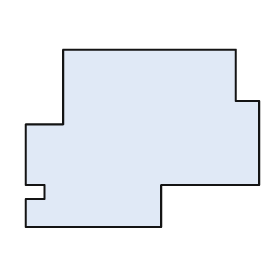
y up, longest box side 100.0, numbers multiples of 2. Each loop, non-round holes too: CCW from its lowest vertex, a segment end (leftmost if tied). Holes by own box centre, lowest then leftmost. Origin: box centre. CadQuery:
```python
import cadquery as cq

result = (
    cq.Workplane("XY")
    .moveTo(-50.0, -38.0)
    .lineTo(8.0, -38.0)
    .lineTo(8.0, -20.0)
    .lineTo(50.0, -20.0)
    .lineTo(50.0, 16.0)
    .lineTo(40.0, 16.0)
    .lineTo(40.0, 38.0)
    .lineTo(-34.0, 38.0)
    .lineTo(-34.0, 6.0)
    .lineTo(-50.0, 6.0)
    .lineTo(-50.0, -20.0)
    .lineTo(-42.0, -20.0)
    .lineTo(-42.0, -26.0)
    .lineTo(-50.0, -26.0)
    .close()
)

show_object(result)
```